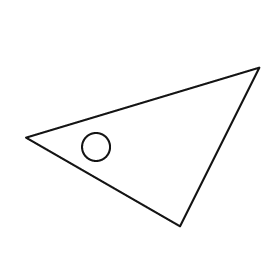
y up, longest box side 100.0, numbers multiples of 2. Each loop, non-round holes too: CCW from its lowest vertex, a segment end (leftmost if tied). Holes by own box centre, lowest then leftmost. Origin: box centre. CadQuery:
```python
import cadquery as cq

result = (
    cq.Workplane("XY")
    .moveTo(16.0, -34.0)
    .lineTo(50.0, 34.0)
    .lineTo(-50.0, 4.0)
    .close()
    .moveTo(-20.0, 0.0)
    .circle(6.0)
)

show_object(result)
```